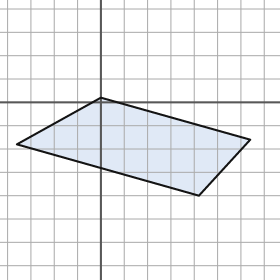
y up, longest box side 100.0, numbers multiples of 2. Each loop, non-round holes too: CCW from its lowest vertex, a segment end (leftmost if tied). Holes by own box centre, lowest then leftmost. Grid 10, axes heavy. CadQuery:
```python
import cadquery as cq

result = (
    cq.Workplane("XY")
    .moveTo(42.0, -40.0)
    .lineTo(64.0, -16.0)
    .lineTo(0.0, 2.0)
    .lineTo(-36.0, -18.0)
    .close()
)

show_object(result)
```